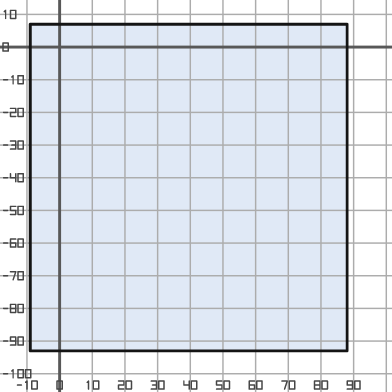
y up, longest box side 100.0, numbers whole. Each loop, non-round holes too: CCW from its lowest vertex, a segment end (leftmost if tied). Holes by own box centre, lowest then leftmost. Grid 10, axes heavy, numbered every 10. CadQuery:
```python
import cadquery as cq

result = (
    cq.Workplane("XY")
    .moveTo(-9.0, -93.0)
    .lineTo(88.0, -93.0)
    .lineTo(88.0, 7.0)
    .lineTo(-9.0, 7.0)
    .close()
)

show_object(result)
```